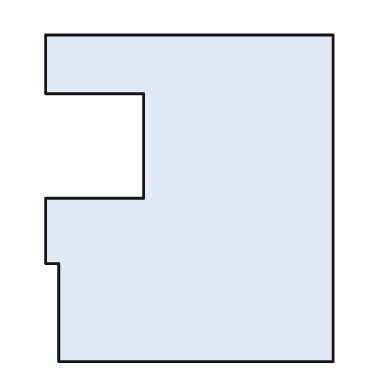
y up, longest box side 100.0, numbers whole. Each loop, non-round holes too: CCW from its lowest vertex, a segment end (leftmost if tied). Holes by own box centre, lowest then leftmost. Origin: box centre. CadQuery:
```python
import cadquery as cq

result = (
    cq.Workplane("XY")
    .moveTo(-40.0, -50.0)
    .lineTo(44.0, -50.0)
    .lineTo(44.0, 50.0)
    .lineTo(-44.0, 50.0)
    .lineTo(-44.0, 32.0)
    .lineTo(-14.0, 32.0)
    .lineTo(-14.0, 0.0)
    .lineTo(-44.0, 0.0)
    .lineTo(-44.0, -20.0)
    .lineTo(-40.0, -20.0)
    .close()
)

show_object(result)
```